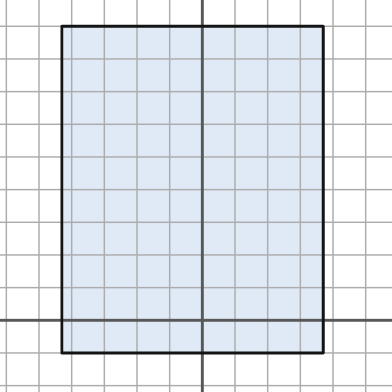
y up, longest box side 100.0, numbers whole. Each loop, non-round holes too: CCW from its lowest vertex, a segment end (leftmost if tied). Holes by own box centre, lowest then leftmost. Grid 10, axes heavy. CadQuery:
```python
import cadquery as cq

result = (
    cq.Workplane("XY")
    .moveTo(-43.0, -10.0)
    .lineTo(37.0, -10.0)
    .lineTo(37.0, 90.0)
    .lineTo(-43.0, 90.0)
    .close()
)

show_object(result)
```